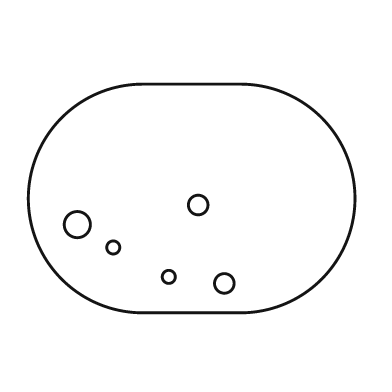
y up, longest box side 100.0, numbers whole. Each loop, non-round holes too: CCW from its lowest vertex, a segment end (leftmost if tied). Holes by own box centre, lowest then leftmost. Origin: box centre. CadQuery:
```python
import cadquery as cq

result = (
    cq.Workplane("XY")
    .moveTo(-15.0, -35.0)
    .lineTo(15.0, -35.0)
    .threePointArc((50.0, 0.0), (15.0, 35.0))
    .lineTo(-15.0, 35.0)
    .threePointArc((-50.0, 0.0), (-15.0, -35.0))
    .close()
    .moveTo(10.0, -26.0)
    .circle(3.0)
    .moveTo(-7.0, -24.0)
    .circle(2.0)
    .moveTo(-24.0, -15.0)
    .circle(2.0)
    .moveTo(-35.0, -8.0)
    .circle(4.0)
    .moveTo(2.0, -2.0)
    .circle(3.0)
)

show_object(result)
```